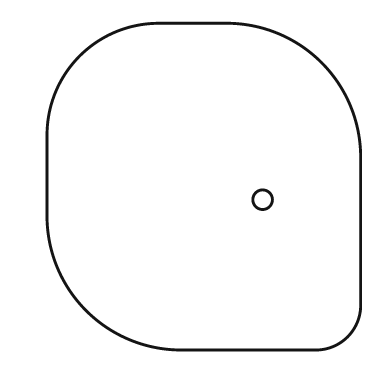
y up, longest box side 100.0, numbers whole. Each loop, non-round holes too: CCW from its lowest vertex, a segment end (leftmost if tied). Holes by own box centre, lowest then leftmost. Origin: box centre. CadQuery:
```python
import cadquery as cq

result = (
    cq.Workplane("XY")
    .moveTo(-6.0, -50.0)
    .lineTo(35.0, -50.0)
    .threePointArc((44.0, -46.0), (48.0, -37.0))
    .lineTo(48.0, 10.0)
    .threePointArc((36.0, 38.0), (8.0, 50.0))
    .lineTo(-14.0, 50.0)
    .threePointArc((-38.0, 40.0), (-48.0, 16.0))
    .lineTo(-48.0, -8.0)
    .threePointArc((-36.0, -38.0), (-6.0, -50.0))
    .close()
    .moveTo(18.0, -4.0)
    .circle(3.0)
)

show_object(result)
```